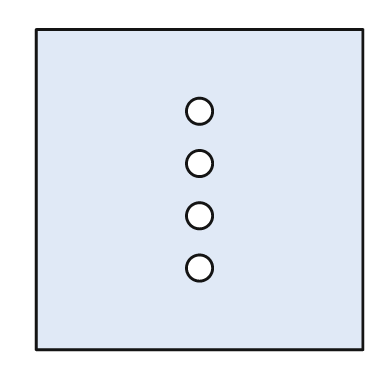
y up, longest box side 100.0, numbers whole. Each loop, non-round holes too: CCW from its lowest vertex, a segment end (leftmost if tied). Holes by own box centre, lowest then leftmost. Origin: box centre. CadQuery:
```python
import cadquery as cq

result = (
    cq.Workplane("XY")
    .moveTo(-50.0, -49.0)
    .lineTo(50.0, -49.0)
    .lineTo(50.0, 49.0)
    .lineTo(-50.0, 49.0)
    .close()
    .moveTo(0.0, -24.0)
    .circle(4.0)
    .moveTo(0.0, -8.0)
    .circle(4.0)
    .moveTo(0.0, 8.0)
    .circle(4.0)
    .moveTo(0.0, 24.0)
    .circle(4.0)
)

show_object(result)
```